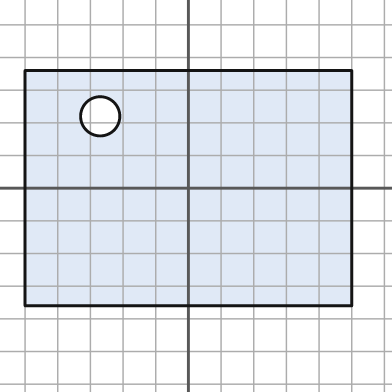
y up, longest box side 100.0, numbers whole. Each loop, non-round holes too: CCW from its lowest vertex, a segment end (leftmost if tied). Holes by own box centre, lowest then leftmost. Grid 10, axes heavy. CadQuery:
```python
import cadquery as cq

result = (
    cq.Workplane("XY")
    .moveTo(-50.0, -36.0)
    .lineTo(50.0, -36.0)
    .lineTo(50.0, 36.0)
    .lineTo(-50.0, 36.0)
    .close()
    .moveTo(-27.0, 22.0)
    .circle(6.0)
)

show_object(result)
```